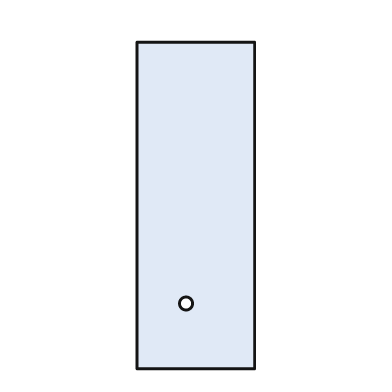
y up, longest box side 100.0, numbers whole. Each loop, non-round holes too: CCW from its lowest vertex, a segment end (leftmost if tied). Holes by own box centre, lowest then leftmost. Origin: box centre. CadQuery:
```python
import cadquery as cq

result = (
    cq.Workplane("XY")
    .moveTo(-18.0, -50.0)
    .lineTo(18.0, -50.0)
    .lineTo(18.0, 50.0)
    .lineTo(-18.0, 50.0)
    .close()
    .moveTo(-3.0, -30.0)
    .circle(2.0)
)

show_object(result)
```